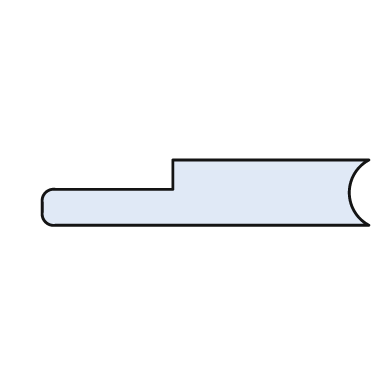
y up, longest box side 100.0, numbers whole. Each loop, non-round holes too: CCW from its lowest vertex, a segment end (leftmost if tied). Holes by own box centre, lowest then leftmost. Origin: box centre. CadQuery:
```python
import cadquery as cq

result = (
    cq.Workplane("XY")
    .moveTo(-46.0, -10.0)
    .lineTo(50.0, -10.0)
    .threePointArc((44.0, 0.0), (50.0, 10.0))
    .lineTo(-10.0, 10.0)
    .lineTo(-10.0, 1.0)
    .lineTo(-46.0, 1.0)
    .threePointArc((-49.0, 0.0), (-50.0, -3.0))
    .lineTo(-50.0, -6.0)
    .threePointArc((-49.0, -9.0), (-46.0, -10.0))
    .close()
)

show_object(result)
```